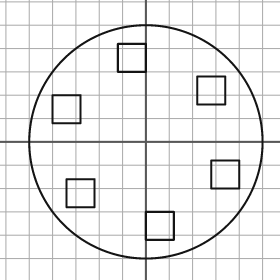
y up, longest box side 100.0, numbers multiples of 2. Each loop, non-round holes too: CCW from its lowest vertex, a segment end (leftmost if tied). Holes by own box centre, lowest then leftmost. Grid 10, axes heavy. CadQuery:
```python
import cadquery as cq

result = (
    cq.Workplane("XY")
    .moveTo(0.0, 0.0)
    .circle(50.0)
    .moveTo(0.0, -42.0)
    .lineTo(12.0, -42.0)
    .lineTo(12.0, -30.0)
    .lineTo(0.0, -30.0)
    .close()
    .moveTo(-34.0, -28.0)
    .lineTo(-22.0, -28.0)
    .lineTo(-22.0, -16.0)
    .lineTo(-34.0, -16.0)
    .close()
    .moveTo(28.0, -20.0)
    .lineTo(40.0, -20.0)
    .lineTo(40.0, -8.0)
    .lineTo(28.0, -8.0)
    .close()
    .moveTo(-40.0, 8.0)
    .lineTo(-28.0, 8.0)
    .lineTo(-28.0, 20.0)
    .lineTo(-40.0, 20.0)
    .close()
    .moveTo(22.0, 16.0)
    .lineTo(34.0, 16.0)
    .lineTo(34.0, 28.0)
    .lineTo(22.0, 28.0)
    .close()
    .moveTo(-12.0, 30.0)
    .lineTo(0.0, 30.0)
    .lineTo(0.0, 42.0)
    .lineTo(-12.0, 42.0)
    .close()
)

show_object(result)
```